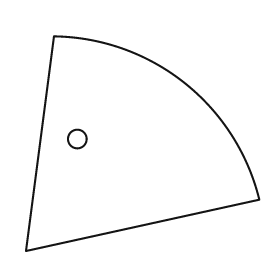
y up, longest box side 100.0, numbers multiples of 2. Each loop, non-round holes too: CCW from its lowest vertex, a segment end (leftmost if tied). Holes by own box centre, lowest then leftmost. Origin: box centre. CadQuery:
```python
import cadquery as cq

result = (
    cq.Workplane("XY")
    .moveTo(-50.0, -46.0)
    .lineTo(50.0, -24.0)
    .threePointArc((18.0, 26.0), (-38.0, 46.0))
    .close()
    .moveTo(-28.0, 2.0)
    .circle(4.0)
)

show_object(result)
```